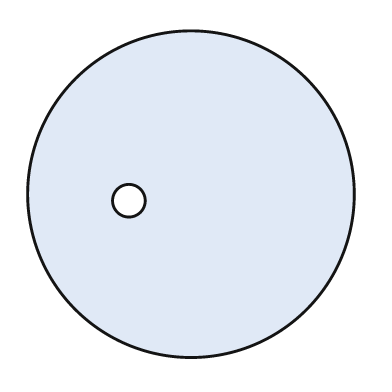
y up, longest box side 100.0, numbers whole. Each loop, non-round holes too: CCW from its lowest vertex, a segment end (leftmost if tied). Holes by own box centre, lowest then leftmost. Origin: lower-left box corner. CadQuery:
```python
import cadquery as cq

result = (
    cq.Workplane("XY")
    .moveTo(50.0, 50.0)
    .circle(50.0)
    .moveTo(31.0, 48.0)
    .circle(5.0)
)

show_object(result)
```